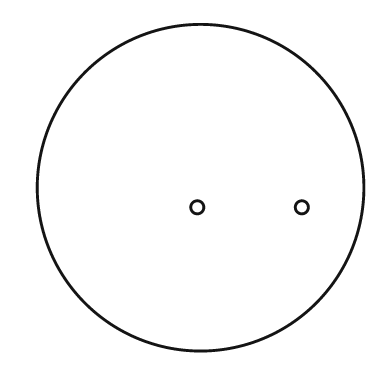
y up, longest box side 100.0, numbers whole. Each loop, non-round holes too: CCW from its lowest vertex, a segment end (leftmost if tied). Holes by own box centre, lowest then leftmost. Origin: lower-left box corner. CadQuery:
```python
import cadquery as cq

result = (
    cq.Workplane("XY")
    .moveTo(50.0, 50.0)
    .circle(50.0)
    .moveTo(49.0, 44.0)
    .circle(2.0)
    .moveTo(81.0, 44.0)
    .circle(2.0)
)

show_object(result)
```